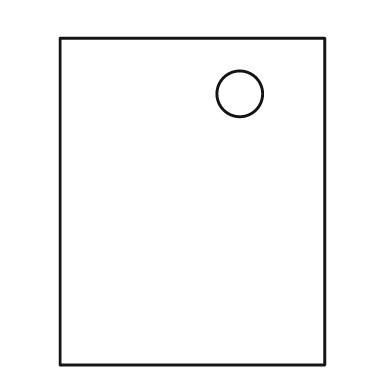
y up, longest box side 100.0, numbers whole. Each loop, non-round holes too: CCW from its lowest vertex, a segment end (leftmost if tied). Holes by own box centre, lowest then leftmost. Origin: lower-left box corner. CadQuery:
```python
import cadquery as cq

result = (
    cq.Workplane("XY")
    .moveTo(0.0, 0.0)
    .lineTo(81.0, 0.0)
    .lineTo(81.0, 100.0)
    .lineTo(0.0, 100.0)
    .close()
    .moveTo(55.0, 83.0)
    .circle(7.0)
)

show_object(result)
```